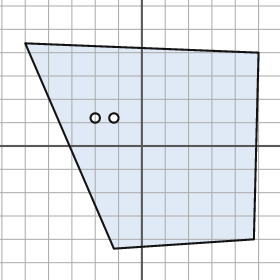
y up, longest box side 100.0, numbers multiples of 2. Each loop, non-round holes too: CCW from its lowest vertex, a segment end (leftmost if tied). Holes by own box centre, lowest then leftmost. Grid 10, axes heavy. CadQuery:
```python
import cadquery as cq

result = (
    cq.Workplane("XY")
    .moveTo(-12.0, -44.0)
    .lineTo(48.0, -40.0)
    .lineTo(50.0, 40.0)
    .lineTo(-50.0, 44.0)
    .close()
    .moveTo(-20.0, 12.0)
    .circle(2.0)
    .moveTo(-12.0, 12.0)
    .circle(2.0)
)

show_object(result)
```